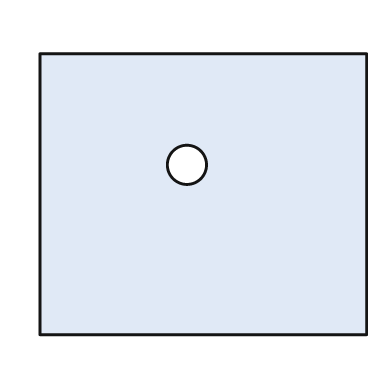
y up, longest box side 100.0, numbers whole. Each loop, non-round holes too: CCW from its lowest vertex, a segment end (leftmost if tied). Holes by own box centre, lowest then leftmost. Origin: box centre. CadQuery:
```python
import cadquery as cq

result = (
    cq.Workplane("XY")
    .moveTo(-50.0, -43.0)
    .lineTo(50.0, -43.0)
    .lineTo(50.0, 43.0)
    .lineTo(-50.0, 43.0)
    .close()
    .moveTo(-5.0, 9.0)
    .circle(6.0)
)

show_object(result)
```